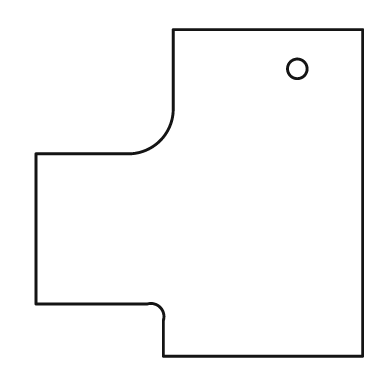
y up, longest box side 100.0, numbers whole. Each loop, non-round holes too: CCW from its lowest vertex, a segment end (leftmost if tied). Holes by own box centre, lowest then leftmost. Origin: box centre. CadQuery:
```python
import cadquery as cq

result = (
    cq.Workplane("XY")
    .moveTo(-11.0, -50.0)
    .lineTo(50.0, -50.0)
    .lineTo(50.0, 50.0)
    .lineTo(-8.0, 50.0)
    .lineTo(-8.0, 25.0)
    .threePointArc((-12.0, 16.0), (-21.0, 12.0))
    .lineTo(-50.0, 12.0)
    .lineTo(-50.0, -34.0)
    .lineTo(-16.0, -34.0)
    .threePointArc((-12.0, -35.0), (-11.0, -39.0))
    .close()
    .moveTo(30.0, 38.0)
    .circle(3.0)
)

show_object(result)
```